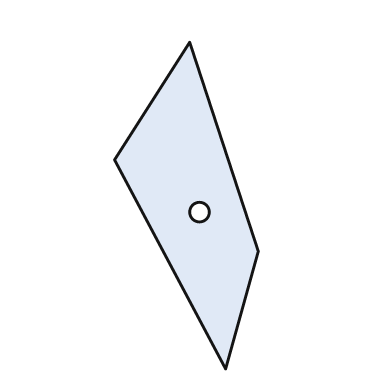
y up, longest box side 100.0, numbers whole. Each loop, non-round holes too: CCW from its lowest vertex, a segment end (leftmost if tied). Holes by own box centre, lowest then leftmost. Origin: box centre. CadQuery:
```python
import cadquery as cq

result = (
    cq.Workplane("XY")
    .moveTo(12.0, -50.0)
    .lineTo(22.0, -14.0)
    .lineTo(1.0, 50.0)
    .lineTo(-22.0, 14.0)
    .close()
    .moveTo(4.0, -2.0)
    .circle(3.0)
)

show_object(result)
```